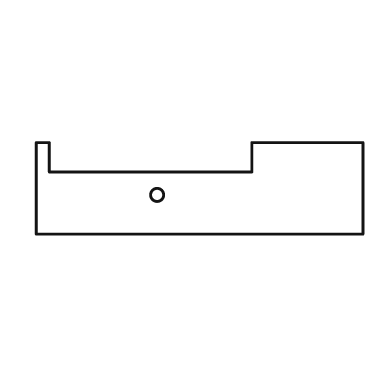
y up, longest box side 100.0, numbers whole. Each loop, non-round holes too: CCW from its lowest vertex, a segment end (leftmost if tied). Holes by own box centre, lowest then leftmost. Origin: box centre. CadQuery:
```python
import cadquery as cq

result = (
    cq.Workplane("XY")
    .moveTo(-50.0, -14.0)
    .lineTo(50.0, -14.0)
    .lineTo(50.0, 14.0)
    .lineTo(16.0, 14.0)
    .lineTo(16.0, 5.0)
    .lineTo(-46.0, 5.0)
    .lineTo(-46.0, 14.0)
    .lineTo(-50.0, 14.0)
    .close()
    .moveTo(-13.0, -2.0)
    .circle(2.0)
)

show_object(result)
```